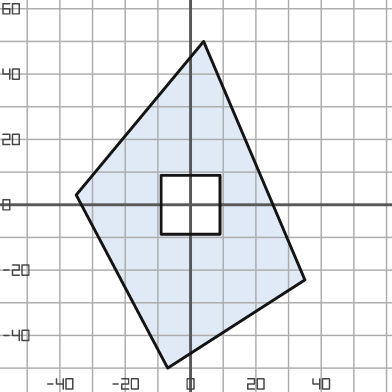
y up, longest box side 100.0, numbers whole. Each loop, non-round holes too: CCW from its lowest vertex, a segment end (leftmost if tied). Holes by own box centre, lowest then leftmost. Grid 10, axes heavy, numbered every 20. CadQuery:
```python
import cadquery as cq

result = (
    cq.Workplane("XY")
    .moveTo(-7.0, -50.0)
    .lineTo(35.0, -23.0)
    .lineTo(4.0, 50.0)
    .lineTo(-35.0, 3.0)
    .close()
    .moveTo(-9.0, -9.0)
    .lineTo(9.0, -9.0)
    .lineTo(9.0, 9.0)
    .lineTo(-9.0, 9.0)
    .close()
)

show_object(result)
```